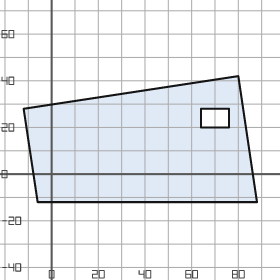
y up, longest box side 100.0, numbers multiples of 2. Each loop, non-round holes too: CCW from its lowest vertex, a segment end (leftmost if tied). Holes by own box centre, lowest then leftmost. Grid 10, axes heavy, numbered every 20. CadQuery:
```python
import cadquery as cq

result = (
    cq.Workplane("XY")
    .moveTo(-6.0, -12.0)
    .lineTo(88.0, -12.0)
    .lineTo(80.0, 42.0)
    .lineTo(-12.0, 28.0)
    .close()
    .moveTo(64.0, 20.0)
    .lineTo(76.0, 20.0)
    .lineTo(76.0, 28.0)
    .lineTo(64.0, 28.0)
    .close()
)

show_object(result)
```